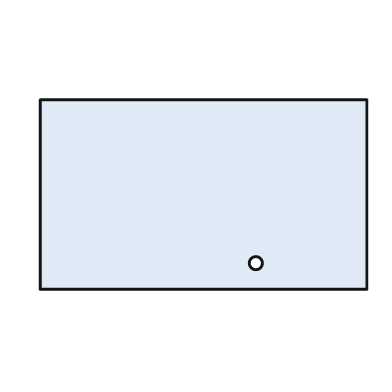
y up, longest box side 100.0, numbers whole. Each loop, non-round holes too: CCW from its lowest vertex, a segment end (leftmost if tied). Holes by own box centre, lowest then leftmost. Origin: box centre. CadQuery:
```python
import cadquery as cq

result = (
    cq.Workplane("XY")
    .moveTo(-50.0, -29.0)
    .lineTo(50.0, -29.0)
    .lineTo(50.0, 29.0)
    .lineTo(-50.0, 29.0)
    .close()
    .moveTo(16.0, -21.0)
    .circle(2.0)
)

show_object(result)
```